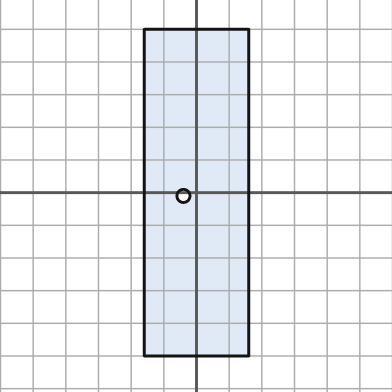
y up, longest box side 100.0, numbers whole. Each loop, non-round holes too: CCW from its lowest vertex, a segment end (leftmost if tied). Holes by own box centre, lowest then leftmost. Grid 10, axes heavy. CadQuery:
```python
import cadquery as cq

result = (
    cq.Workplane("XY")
    .moveTo(-16.0, -50.0)
    .lineTo(16.0, -50.0)
    .lineTo(16.0, 50.0)
    .lineTo(-16.0, 50.0)
    .close()
    .moveTo(-4.0, -1.0)
    .circle(2.0)
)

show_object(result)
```